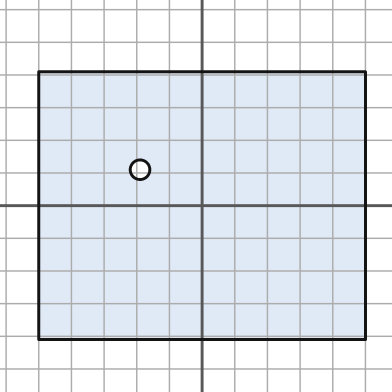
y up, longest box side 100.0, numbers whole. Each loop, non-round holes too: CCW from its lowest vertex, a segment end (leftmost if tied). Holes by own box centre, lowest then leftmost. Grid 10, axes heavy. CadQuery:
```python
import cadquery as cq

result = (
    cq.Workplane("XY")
    .moveTo(-50.0, -41.0)
    .lineTo(50.0, -41.0)
    .lineTo(50.0, 41.0)
    .lineTo(-50.0, 41.0)
    .close()
    .moveTo(-19.0, 11.0)
    .circle(3.0)
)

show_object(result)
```